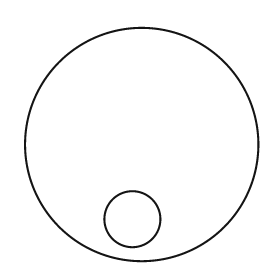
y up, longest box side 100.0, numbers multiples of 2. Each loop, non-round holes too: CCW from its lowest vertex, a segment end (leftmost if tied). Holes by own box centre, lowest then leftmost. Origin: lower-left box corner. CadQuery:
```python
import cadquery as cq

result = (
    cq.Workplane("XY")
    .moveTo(50.0, 50.0)
    .circle(50.0)
    .moveTo(46.0, 18.0)
    .circle(12.0)
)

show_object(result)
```